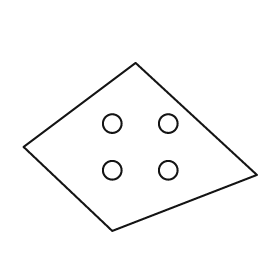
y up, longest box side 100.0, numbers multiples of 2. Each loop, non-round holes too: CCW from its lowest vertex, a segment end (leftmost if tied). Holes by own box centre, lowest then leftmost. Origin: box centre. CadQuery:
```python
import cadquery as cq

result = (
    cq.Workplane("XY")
    .moveTo(-12.0, -36.0)
    .lineTo(50.0, -12.0)
    .lineTo(-2.0, 36.0)
    .lineTo(-50.0, 0.0)
    .close()
    .moveTo(-12.0, -10.0)
    .circle(4.0)
    .moveTo(12.0, -10.0)
    .circle(4.0)
    .moveTo(-12.0, 10.0)
    .circle(4.0)
    .moveTo(12.0, 10.0)
    .circle(4.0)
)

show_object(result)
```